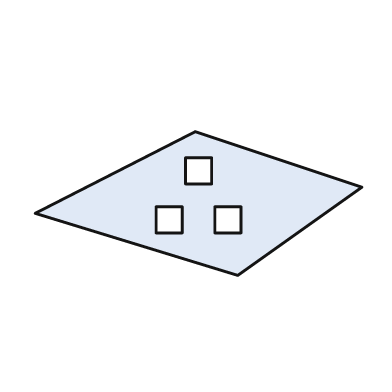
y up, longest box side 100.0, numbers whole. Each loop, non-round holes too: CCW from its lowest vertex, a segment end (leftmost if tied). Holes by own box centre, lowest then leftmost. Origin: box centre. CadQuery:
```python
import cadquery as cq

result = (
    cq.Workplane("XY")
    .moveTo(12.0, -22.0)
    .lineTo(50.0, 5.0)
    .lineTo(-1.0, 22.0)
    .lineTo(-50.0, -3.0)
    .close()
    .moveTo(-13.0, -9.0)
    .lineTo(-5.0, -9.0)
    .lineTo(-5.0, -1.0)
    .lineTo(-13.0, -1.0)
    .close()
    .moveTo(5.0, -9.0)
    .lineTo(13.0, -9.0)
    .lineTo(13.0, -1.0)
    .lineTo(5.0, -1.0)
    .close()
    .moveTo(-4.0, 6.0)
    .lineTo(4.0, 6.0)
    .lineTo(4.0, 14.0)
    .lineTo(-4.0, 14.0)
    .close()
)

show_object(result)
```